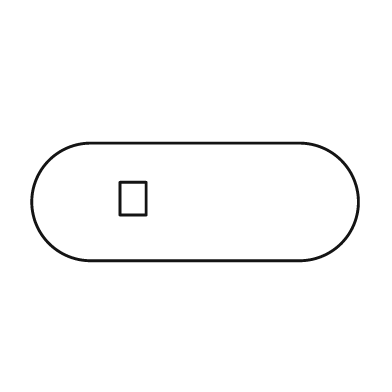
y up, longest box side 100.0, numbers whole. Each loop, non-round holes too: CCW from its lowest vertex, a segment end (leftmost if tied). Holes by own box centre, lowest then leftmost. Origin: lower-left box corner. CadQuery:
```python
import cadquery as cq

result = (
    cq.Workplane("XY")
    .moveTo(18.0, 0.0)
    .lineTo(82.0, 0.0)
    .threePointArc((100.0, 18.0), (82.0, 36.0))
    .lineTo(18.0, 36.0)
    .threePointArc((0.0, 18.0), (18.0, 0.0))
    .close()
    .moveTo(27.0, 14.0)
    .lineTo(35.0, 14.0)
    .lineTo(35.0, 24.0)
    .lineTo(27.0, 24.0)
    .close()
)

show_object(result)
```